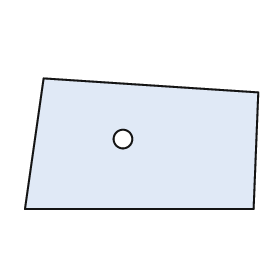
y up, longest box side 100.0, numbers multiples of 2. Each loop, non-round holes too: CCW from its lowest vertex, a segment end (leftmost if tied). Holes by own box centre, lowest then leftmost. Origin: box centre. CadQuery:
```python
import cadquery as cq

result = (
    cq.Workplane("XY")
    .moveTo(-50.0, -28.0)
    .lineTo(48.0, -28.0)
    .lineTo(50.0, 22.0)
    .lineTo(-42.0, 28.0)
    .close()
    .moveTo(-8.0, 2.0)
    .circle(4.0)
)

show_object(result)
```